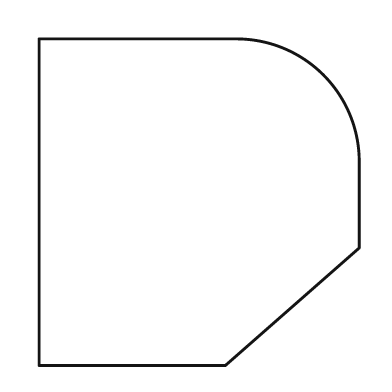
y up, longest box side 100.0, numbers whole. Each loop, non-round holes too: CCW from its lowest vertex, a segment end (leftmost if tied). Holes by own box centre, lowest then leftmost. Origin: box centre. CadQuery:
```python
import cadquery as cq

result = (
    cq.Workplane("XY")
    .moveTo(-49.0, -50.0)
    .lineTo(8.0, -50.0)
    .lineTo(49.0, -14.0)
    .lineTo(49.0, 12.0)
    .threePointArc((38.0, 39.0), (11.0, 50.0))
    .lineTo(-49.0, 50.0)
    .close()
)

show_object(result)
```